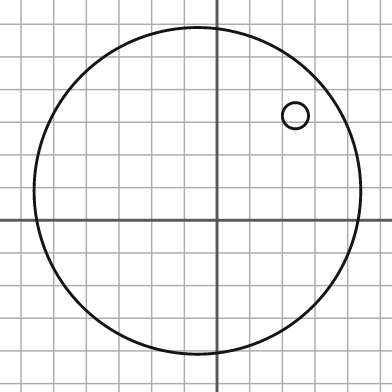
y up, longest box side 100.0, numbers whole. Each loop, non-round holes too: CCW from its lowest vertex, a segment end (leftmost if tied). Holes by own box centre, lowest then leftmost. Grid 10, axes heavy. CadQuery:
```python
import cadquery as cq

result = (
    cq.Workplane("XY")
    .moveTo(-6.0, 9.0)
    .circle(50.0)
    .moveTo(24.0, 32.0)
    .circle(4.0)
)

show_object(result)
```